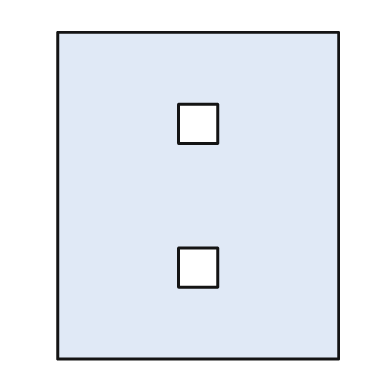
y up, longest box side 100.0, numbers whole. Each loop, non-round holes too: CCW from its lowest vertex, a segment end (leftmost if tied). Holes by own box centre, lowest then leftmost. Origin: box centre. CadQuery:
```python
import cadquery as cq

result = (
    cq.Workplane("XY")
    .moveTo(-43.0, -50.0)
    .lineTo(43.0, -50.0)
    .lineTo(43.0, 50.0)
    .lineTo(-43.0, 50.0)
    .close()
    .moveTo(-6.0, -28.0)
    .lineTo(6.0, -28.0)
    .lineTo(6.0, -16.0)
    .lineTo(-6.0, -16.0)
    .close()
    .moveTo(-6.0, 16.0)
    .lineTo(6.0, 16.0)
    .lineTo(6.0, 28.0)
    .lineTo(-6.0, 28.0)
    .close()
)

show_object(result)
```